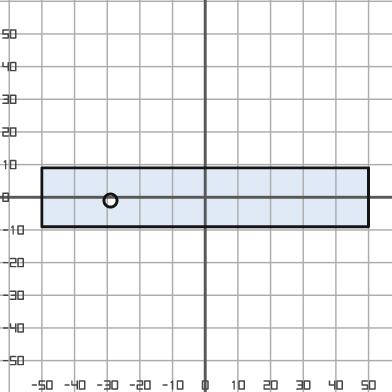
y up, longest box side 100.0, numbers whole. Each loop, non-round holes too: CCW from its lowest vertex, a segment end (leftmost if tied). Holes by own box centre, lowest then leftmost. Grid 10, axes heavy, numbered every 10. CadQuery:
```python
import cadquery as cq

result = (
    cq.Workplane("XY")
    .moveTo(-50.0, -9.0)
    .lineTo(50.0, -9.0)
    .lineTo(50.0, 9.0)
    .lineTo(-50.0, 9.0)
    .close()
    .moveTo(-29.0, -1.0)
    .circle(2.0)
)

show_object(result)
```